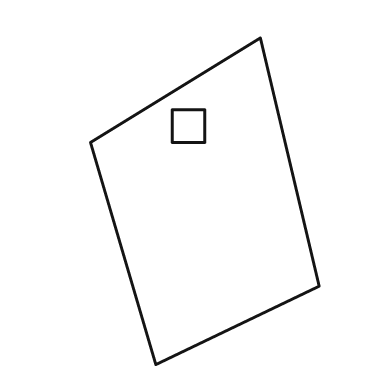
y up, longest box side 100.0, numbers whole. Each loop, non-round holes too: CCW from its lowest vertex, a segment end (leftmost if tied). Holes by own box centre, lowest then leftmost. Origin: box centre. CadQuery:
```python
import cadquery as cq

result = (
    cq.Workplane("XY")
    .moveTo(-15.0, -50.0)
    .lineTo(35.0, -26.0)
    .lineTo(17.0, 50.0)
    .lineTo(-35.0, 18.0)
    .close()
    .moveTo(-10.0, 18.0)
    .lineTo(0.0, 18.0)
    .lineTo(0.0, 28.0)
    .lineTo(-10.0, 28.0)
    .close()
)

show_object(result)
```